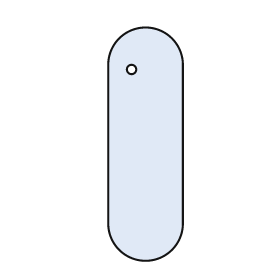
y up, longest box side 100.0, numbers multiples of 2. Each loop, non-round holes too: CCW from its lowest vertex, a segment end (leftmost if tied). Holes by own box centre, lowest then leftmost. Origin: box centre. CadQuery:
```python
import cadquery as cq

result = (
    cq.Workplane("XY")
    .moveTo(-16.0, -34.0)
    .threePointArc((0.0, -50.0), (16.0, -34.0))
    .lineTo(16.0, 34.0)
    .threePointArc((0.0, 50.0), (-16.0, 34.0))
    .close()
    .moveTo(-6.0, 32.0)
    .circle(2.0)
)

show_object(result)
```